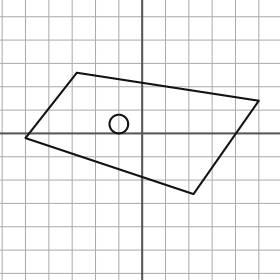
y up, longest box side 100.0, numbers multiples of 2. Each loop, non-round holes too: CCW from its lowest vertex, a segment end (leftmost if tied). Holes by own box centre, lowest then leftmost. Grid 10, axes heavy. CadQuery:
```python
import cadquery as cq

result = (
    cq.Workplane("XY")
    .moveTo(22.0, -26.0)
    .lineTo(50.0, 14.0)
    .lineTo(-28.0, 26.0)
    .lineTo(-50.0, -2.0)
    .close()
    .moveTo(-10.0, 4.0)
    .circle(4.0)
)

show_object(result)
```